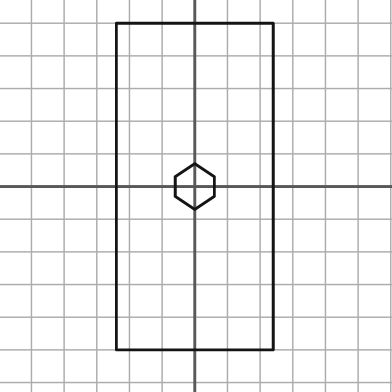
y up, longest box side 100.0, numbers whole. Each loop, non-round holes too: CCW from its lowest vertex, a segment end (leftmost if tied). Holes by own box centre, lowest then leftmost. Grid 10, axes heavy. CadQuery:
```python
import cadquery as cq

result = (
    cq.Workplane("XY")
    .moveTo(-24.0, -50.0)
    .lineTo(24.0, -50.0)
    .lineTo(24.0, 50.0)
    .lineTo(-24.0, 50.0)
    .close()
    .moveTo(0.0, -7.0)
    .lineTo(6.0, -3.0)
    .lineTo(6.0, 3.0)
    .lineTo(0.0, 7.0)
    .lineTo(-6.0, 3.0)
    .lineTo(-6.0, -3.0)
    .close()
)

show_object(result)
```